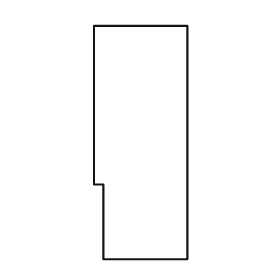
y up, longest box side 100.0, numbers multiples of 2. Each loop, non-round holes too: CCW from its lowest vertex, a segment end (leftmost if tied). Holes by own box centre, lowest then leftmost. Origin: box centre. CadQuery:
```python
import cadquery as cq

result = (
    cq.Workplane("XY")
    .moveTo(-16.0, -50.0)
    .lineTo(20.0, -50.0)
    .lineTo(20.0, 50.0)
    .lineTo(-20.0, 50.0)
    .lineTo(-20.0, -18.0)
    .lineTo(-16.0, -18.0)
    .close()
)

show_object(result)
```